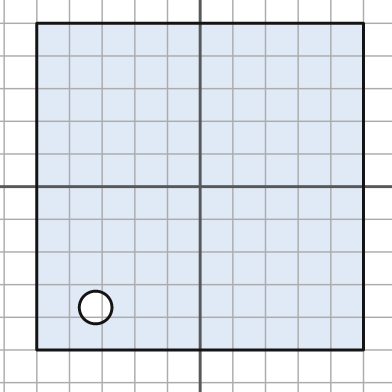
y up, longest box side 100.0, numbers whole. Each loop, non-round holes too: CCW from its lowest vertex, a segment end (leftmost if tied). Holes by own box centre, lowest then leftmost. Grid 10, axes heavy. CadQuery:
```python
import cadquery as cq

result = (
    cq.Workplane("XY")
    .moveTo(-50.0, -50.0)
    .lineTo(50.0, -50.0)
    .lineTo(50.0, 50.0)
    .lineTo(-50.0, 50.0)
    .close()
    .moveTo(-32.0, -37.0)
    .circle(5.0)
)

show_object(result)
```